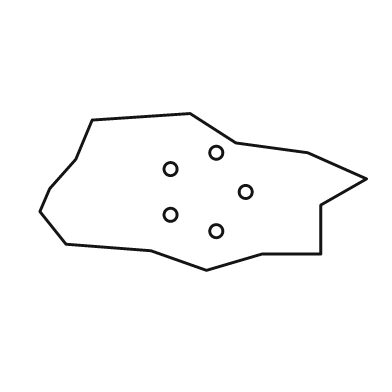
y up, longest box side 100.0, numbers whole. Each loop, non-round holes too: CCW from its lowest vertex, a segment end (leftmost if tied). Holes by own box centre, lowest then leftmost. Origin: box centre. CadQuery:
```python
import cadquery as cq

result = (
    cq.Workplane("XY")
    .moveTo(1.0, -24.0)
    .lineTo(18.0, -19.0)
    .lineTo(36.0, -19.0)
    .lineTo(36.0, -4.0)
    .lineTo(50.0, 4.0)
    .lineTo(32.0, 12.0)
    .lineTo(10.0, 15.0)
    .lineTo(-4.0, 24.0)
    .lineTo(-34.0, 22.0)
    .lineTo(-39.0, 10.0)
    .lineTo(-47.0, 1.0)
    .lineTo(-50.0, -6.0)
    .lineTo(-42.0, -16.0)
    .lineTo(-16.0, -18.0)
    .close()
    .moveTo(4.0, -12.0)
    .circle(2.0)
    .moveTo(-10.0, -7.0)
    .circle(2.0)
    .moveTo(13.0, 0.0)
    .circle(2.0)
    .moveTo(-10.0, 7.0)
    .circle(2.0)
    .moveTo(4.0, 12.0)
    .circle(2.0)
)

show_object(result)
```